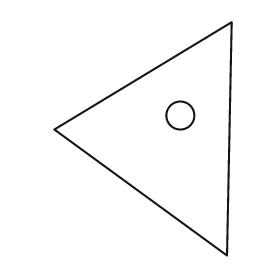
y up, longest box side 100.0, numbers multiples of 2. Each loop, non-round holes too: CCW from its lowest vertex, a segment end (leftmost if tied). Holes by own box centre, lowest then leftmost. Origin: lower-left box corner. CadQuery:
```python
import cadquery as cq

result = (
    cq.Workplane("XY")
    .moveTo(74.0, 0.0)
    .lineTo(76.0, 100.0)
    .lineTo(0.0, 54.0)
    .close()
    .moveTo(54.0, 60.0)
    .circle(6.0)
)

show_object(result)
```